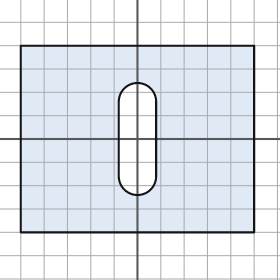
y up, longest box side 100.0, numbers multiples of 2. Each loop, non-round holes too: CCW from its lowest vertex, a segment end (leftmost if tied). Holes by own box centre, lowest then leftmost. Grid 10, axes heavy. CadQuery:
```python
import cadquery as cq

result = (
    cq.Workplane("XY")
    .moveTo(-50.0, -40.0)
    .lineTo(50.0, -40.0)
    .lineTo(50.0, 40.0)
    .lineTo(-50.0, 40.0)
    .close()
    .moveTo(-8.0, -16.0)
    .threePointArc((0.0, -24.0), (8.0, -16.0))
    .lineTo(8.0, 16.0)
    .threePointArc((0.0, 24.0), (-8.0, 16.0))
    .close()
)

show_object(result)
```